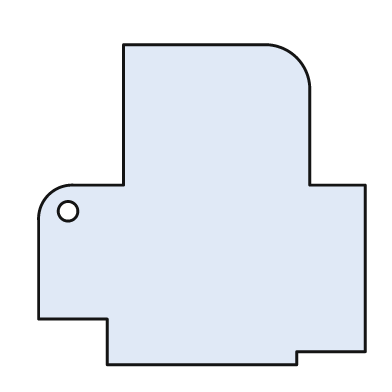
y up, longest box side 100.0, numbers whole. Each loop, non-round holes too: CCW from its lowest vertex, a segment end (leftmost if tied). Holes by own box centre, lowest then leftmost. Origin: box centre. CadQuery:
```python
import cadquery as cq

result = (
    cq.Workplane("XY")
    .moveTo(-29.0, -49.0)
    .lineTo(29.0, -49.0)
    .lineTo(29.0, -45.0)
    .lineTo(50.0, -45.0)
    .lineTo(50.0, 6.0)
    .lineTo(33.0, 6.0)
    .lineTo(33.0, 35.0)
    .threePointArc((29.0, 45.0), (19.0, 49.0))
    .lineTo(-24.0, 49.0)
    .lineTo(-24.0, 6.0)
    .lineTo(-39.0, 6.0)
    .threePointArc((-47.0, 3.0), (-50.0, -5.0))
    .lineTo(-50.0, -35.0)
    .lineTo(-29.0, -35.0)
    .close()
    .moveTo(-41.0, -2.0)
    .circle(3.0)
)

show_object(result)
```